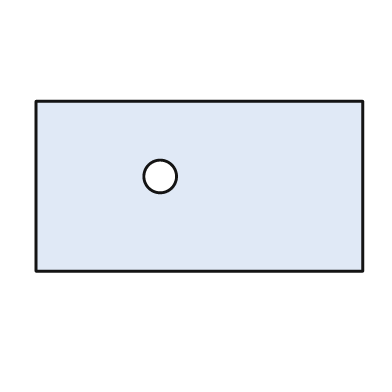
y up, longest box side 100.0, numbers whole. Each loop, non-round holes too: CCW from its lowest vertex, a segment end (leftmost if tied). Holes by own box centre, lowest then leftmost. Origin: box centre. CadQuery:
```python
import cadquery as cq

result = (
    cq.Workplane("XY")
    .moveTo(-50.0, -26.0)
    .lineTo(50.0, -26.0)
    .lineTo(50.0, 26.0)
    .lineTo(-50.0, 26.0)
    .close()
    .moveTo(-12.0, 3.0)
    .circle(5.0)
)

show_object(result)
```